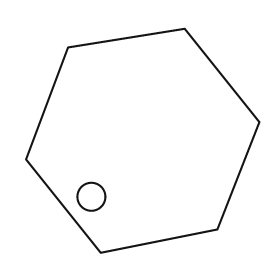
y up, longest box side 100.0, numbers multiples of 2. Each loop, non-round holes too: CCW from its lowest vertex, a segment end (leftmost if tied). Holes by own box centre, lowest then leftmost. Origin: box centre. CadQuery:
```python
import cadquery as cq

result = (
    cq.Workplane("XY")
    .moveTo(-18.0, -48.0)
    .lineTo(32.0, -38.0)
    .lineTo(50.0, 8.0)
    .lineTo(18.0, 48.0)
    .lineTo(-32.0, 40.0)
    .lineTo(-50.0, -8.0)
    .close()
    .moveTo(-22.0, -24.0)
    .circle(6.0)
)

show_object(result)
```